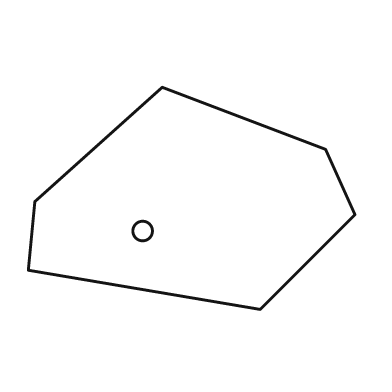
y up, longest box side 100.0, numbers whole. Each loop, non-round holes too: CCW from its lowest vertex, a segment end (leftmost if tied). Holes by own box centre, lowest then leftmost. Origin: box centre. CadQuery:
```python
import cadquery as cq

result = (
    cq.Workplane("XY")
    .moveTo(21.0, -34.0)
    .lineTo(50.0, -5.0)
    .lineTo(41.0, 15.0)
    .lineTo(-9.0, 34.0)
    .lineTo(-48.0, -1.0)
    .lineTo(-50.0, -22.0)
    .close()
    .moveTo(-15.0, -10.0)
    .circle(3.0)
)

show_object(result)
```